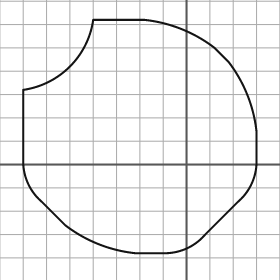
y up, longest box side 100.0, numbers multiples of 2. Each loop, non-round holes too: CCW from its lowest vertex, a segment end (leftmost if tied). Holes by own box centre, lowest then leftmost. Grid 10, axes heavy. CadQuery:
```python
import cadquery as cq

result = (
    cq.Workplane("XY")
    .moveTo(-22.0, -38.0)
    .lineTo(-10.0, -38.0)
    .threePointArc((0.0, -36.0), (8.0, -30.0))
    .lineTo(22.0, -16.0)
    .threePointArc((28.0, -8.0), (30.0, 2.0))
    .lineTo(30.0, 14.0)
    .threePointArc((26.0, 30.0), (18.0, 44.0))
    .lineTo(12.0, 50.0)
    .threePointArc((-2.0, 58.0), (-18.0, 62.0))
    .lineTo(-40.0, 62.0)
    .threePointArc((-50.0, 42.0), (-70.0, 32.0))
    .lineTo(-70.0, 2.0)
    .threePointArc((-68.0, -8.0), (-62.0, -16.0))
    .lineTo(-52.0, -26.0)
    .threePointArc((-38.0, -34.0), (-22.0, -38.0))
    .close()
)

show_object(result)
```